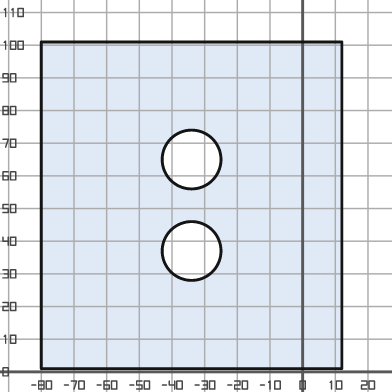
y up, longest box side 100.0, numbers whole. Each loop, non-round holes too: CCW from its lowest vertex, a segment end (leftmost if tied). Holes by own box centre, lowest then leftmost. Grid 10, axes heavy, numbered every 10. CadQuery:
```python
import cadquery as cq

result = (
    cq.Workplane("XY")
    .moveTo(-80.0, 1.0)
    .lineTo(12.0, 1.0)
    .lineTo(12.0, 101.0)
    .lineTo(-80.0, 101.0)
    .close()
    .moveTo(-34.0, 37.0)
    .circle(9.0)
    .moveTo(-34.0, 65.0)
    .circle(9.0)
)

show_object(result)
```